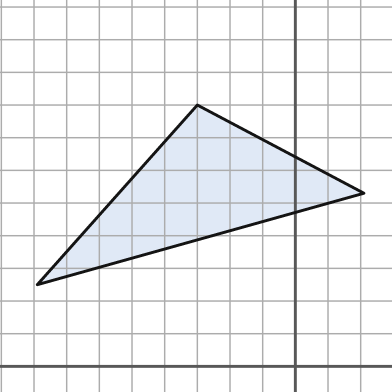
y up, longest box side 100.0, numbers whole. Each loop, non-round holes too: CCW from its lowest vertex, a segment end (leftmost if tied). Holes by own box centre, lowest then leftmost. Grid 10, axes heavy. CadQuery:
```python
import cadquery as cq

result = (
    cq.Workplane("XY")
    .moveTo(-79.0, 25.0)
    .lineTo(21.0, 53.0)
    .lineTo(-30.0, 80.0)
    .close()
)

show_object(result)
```